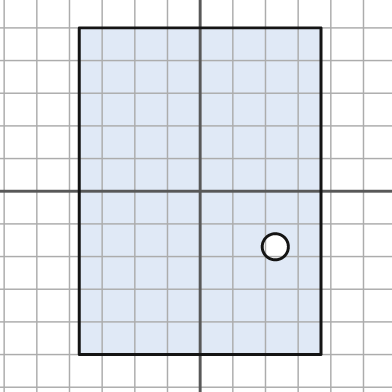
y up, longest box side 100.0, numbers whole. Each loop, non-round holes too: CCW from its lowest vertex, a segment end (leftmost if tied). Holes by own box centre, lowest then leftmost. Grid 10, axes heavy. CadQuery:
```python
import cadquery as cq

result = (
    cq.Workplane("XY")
    .moveTo(-37.0, -50.0)
    .lineTo(37.0, -50.0)
    .lineTo(37.0, 50.0)
    .lineTo(-37.0, 50.0)
    .close()
    .moveTo(23.0, -17.0)
    .circle(4.0)
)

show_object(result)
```